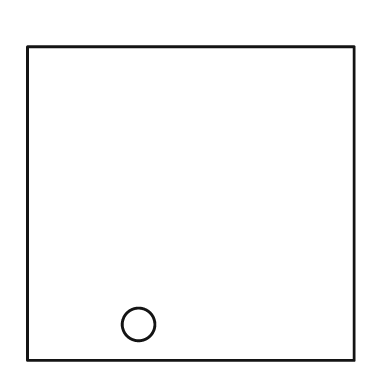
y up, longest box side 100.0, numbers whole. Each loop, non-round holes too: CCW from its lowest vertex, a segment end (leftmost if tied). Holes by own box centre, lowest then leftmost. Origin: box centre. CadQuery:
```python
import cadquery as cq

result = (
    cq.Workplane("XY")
    .moveTo(-50.0, -48.0)
    .lineTo(50.0, -48.0)
    .lineTo(50.0, 48.0)
    .lineTo(-50.0, 48.0)
    .close()
    .moveTo(-16.0, -37.0)
    .circle(5.0)
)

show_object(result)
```